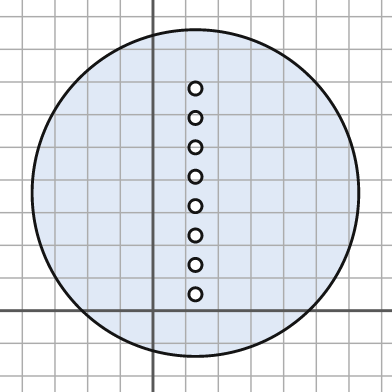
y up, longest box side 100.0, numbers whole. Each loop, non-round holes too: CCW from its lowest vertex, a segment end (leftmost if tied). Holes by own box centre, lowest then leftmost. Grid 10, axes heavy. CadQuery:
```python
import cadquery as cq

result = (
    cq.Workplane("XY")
    .moveTo(13.0, 36.0)
    .circle(50.0)
    .moveTo(13.0, 5.0)
    .circle(2.0)
    .moveTo(13.0, 14.0)
    .circle(2.0)
    .moveTo(13.0, 23.0)
    .circle(2.0)
    .moveTo(13.0, 32.0)
    .circle(2.0)
    .moveTo(13.0, 41.0)
    .circle(2.0)
    .moveTo(13.0, 50.0)
    .circle(2.0)
    .moveTo(13.0, 59.0)
    .circle(2.0)
    .moveTo(13.0, 68.0)
    .circle(2.0)
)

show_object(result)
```